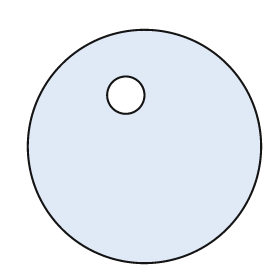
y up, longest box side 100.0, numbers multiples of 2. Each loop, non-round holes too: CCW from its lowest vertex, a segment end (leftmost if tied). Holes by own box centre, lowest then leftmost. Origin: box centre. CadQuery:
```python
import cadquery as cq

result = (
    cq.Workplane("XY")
    .moveTo(0.0, 0.0)
    .circle(50.0)
    .moveTo(-8.0, 22.0)
    .circle(8.0)
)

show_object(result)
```